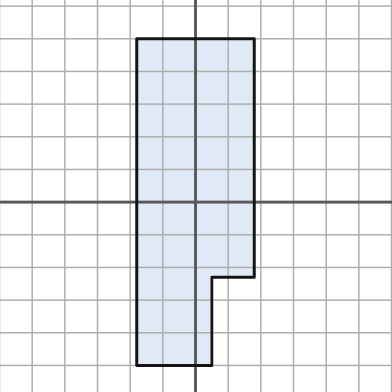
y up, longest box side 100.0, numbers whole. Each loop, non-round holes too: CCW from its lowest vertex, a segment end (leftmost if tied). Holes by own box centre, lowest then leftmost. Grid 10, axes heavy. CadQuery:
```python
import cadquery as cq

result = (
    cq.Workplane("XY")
    .moveTo(-18.0, -50.0)
    .lineTo(5.0, -50.0)
    .lineTo(5.0, -23.0)
    .lineTo(18.0, -23.0)
    .lineTo(18.0, 50.0)
    .lineTo(-18.0, 50.0)
    .close()
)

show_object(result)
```